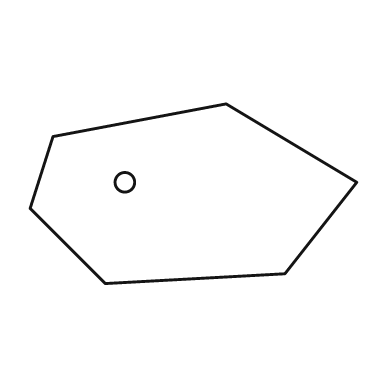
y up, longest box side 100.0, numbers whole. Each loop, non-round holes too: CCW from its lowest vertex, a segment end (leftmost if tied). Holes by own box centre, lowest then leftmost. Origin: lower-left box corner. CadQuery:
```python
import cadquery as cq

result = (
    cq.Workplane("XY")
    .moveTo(23.0, 0.0)
    .lineTo(78.0, 3.0)
    .lineTo(100.0, 31.0)
    .lineTo(60.0, 55.0)
    .lineTo(7.0, 45.0)
    .lineTo(0.0, 23.0)
    .close()
    .moveTo(29.0, 31.0)
    .circle(3.0)
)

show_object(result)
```